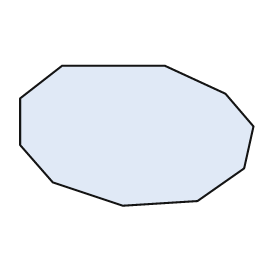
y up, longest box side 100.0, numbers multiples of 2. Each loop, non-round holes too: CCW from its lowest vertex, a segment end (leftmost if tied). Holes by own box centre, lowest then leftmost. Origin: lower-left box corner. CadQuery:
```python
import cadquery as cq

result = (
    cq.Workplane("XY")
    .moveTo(44.0, 0.0)
    .lineTo(76.0, 2.0)
    .lineTo(96.0, 16.0)
    .lineTo(100.0, 34.0)
    .lineTo(88.0, 48.0)
    .lineTo(62.0, 60.0)
    .lineTo(18.0, 60.0)
    .lineTo(0.0, 46.0)
    .lineTo(0.0, 26.0)
    .lineTo(14.0, 10.0)
    .close()
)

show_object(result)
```